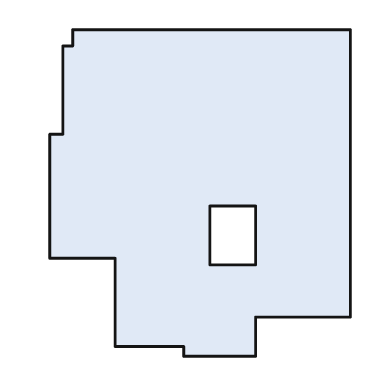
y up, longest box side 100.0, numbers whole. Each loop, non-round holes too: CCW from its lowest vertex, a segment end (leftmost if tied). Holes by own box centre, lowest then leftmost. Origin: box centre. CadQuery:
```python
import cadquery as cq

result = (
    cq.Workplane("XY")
    .moveTo(-5.0, -50.0)
    .lineTo(17.0, -50.0)
    .lineTo(17.0, -38.0)
    .lineTo(46.0, -38.0)
    .lineTo(46.0, 50.0)
    .lineTo(-39.0, 50.0)
    .lineTo(-39.0, 45.0)
    .lineTo(-42.0, 45.0)
    .lineTo(-42.0, 18.0)
    .lineTo(-46.0, 18.0)
    .lineTo(-46.0, -20.0)
    .lineTo(-26.0, -20.0)
    .lineTo(-26.0, -47.0)
    .lineTo(-5.0, -47.0)
    .close()
    .moveTo(3.0, -22.0)
    .lineTo(17.0, -22.0)
    .lineTo(17.0, -4.0)
    .lineTo(3.0, -4.0)
    .close()
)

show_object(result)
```